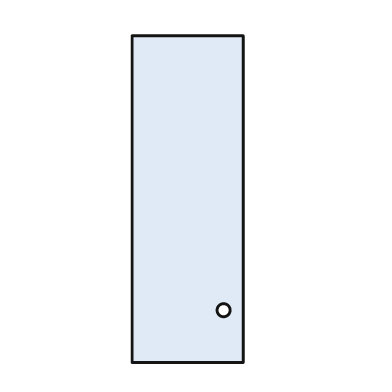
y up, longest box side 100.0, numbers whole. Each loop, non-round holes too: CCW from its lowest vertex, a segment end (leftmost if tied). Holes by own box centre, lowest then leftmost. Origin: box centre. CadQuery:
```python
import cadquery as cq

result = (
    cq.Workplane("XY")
    .moveTo(-17.0, -50.0)
    .lineTo(17.0, -50.0)
    .lineTo(17.0, 50.0)
    .lineTo(-17.0, 50.0)
    .close()
    .moveTo(11.0, -34.0)
    .circle(2.0)
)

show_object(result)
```